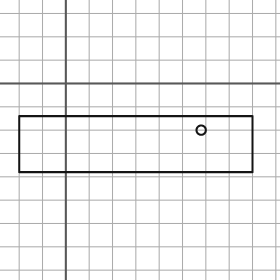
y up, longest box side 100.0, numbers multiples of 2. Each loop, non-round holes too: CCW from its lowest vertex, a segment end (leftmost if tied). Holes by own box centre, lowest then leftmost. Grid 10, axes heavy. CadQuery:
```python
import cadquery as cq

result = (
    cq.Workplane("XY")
    .moveTo(-20.0, -38.0)
    .lineTo(80.0, -38.0)
    .lineTo(80.0, -14.0)
    .lineTo(-20.0, -14.0)
    .close()
    .moveTo(58.0, -20.0)
    .circle(2.0)
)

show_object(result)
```